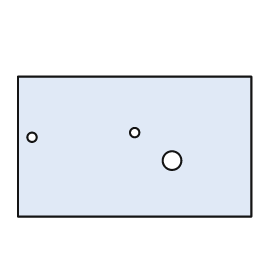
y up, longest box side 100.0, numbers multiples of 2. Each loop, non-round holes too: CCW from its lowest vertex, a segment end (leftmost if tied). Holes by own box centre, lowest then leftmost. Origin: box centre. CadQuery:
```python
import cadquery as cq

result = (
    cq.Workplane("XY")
    .moveTo(-50.0, -30.0)
    .lineTo(50.0, -30.0)
    .lineTo(50.0, 30.0)
    .lineTo(-50.0, 30.0)
    .close()
    .moveTo(16.0, -6.0)
    .circle(4.0)
    .moveTo(-44.0, 4.0)
    .circle(2.0)
    .moveTo(0.0, 6.0)
    .circle(2.0)
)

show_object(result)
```